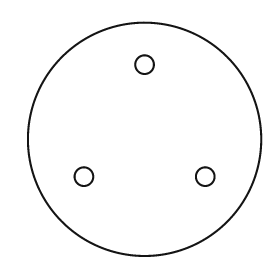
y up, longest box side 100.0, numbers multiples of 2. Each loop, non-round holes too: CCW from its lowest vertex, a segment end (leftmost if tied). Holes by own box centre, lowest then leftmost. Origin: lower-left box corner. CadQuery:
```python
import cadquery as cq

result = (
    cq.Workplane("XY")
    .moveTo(50.0, 50.0)
    .circle(50.0)
    .moveTo(24.0, 34.0)
    .circle(4.0)
    .moveTo(76.0, 34.0)
    .circle(4.0)
    .moveTo(50.0, 82.0)
    .circle(4.0)
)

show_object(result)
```